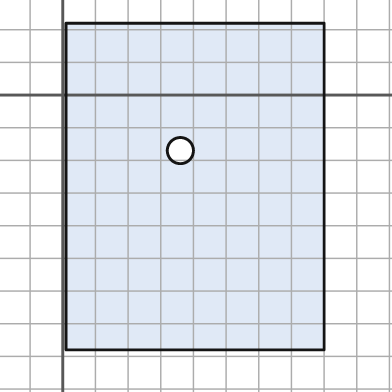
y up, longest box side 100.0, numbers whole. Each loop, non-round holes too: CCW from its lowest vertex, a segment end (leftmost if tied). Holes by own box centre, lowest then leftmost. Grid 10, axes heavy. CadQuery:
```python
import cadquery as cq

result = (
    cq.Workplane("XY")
    .moveTo(1.0, -78.0)
    .lineTo(80.0, -78.0)
    .lineTo(80.0, 22.0)
    .lineTo(1.0, 22.0)
    .close()
    .moveTo(36.0, -17.0)
    .circle(4.0)
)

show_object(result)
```